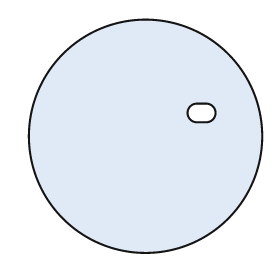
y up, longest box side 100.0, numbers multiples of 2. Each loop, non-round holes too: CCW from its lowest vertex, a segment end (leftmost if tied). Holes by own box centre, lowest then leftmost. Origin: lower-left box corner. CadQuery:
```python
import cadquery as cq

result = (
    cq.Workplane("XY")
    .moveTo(50.0, 50.0)
    .circle(50.0)
    .moveTo(72.0, 56.0)
    .lineTo(76.0, 56.0)
    .threePointArc((80.0, 60.0), (76.0, 64.0))
    .lineTo(72.0, 64.0)
    .threePointArc((68.0, 60.0), (72.0, 56.0))
    .close()
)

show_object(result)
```